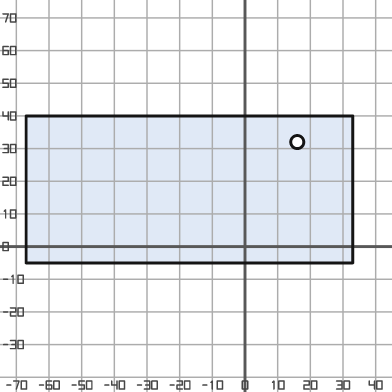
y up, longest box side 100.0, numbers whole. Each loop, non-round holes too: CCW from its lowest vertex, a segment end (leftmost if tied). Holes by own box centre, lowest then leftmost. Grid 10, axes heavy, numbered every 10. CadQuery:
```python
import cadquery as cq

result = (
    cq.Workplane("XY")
    .moveTo(-67.0, -5.0)
    .lineTo(33.0, -5.0)
    .lineTo(33.0, 40.0)
    .lineTo(-67.0, 40.0)
    .close()
    .moveTo(16.0, 32.0)
    .circle(2.0)
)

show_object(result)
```